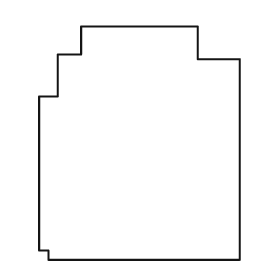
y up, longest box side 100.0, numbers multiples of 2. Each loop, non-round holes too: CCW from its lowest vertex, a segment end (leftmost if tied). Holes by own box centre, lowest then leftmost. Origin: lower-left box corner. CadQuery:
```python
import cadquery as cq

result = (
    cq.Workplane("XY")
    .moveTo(4.0, 0.0)
    .lineTo(86.0, 0.0)
    .lineTo(86.0, 86.0)
    .lineTo(68.0, 86.0)
    .lineTo(68.0, 100.0)
    .lineTo(18.0, 100.0)
    .lineTo(18.0, 88.0)
    .lineTo(8.0, 88.0)
    .lineTo(8.0, 70.0)
    .lineTo(0.0, 70.0)
    .lineTo(0.0, 4.0)
    .lineTo(4.0, 4.0)
    .close()
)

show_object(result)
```